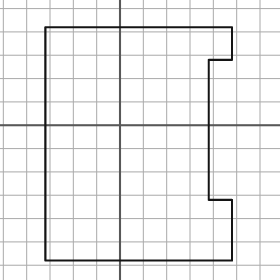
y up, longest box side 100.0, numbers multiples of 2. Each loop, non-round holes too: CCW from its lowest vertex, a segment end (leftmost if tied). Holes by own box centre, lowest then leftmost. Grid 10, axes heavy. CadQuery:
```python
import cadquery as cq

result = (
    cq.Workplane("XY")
    .moveTo(-32.0, -58.0)
    .lineTo(48.0, -58.0)
    .lineTo(48.0, -32.0)
    .lineTo(38.0, -32.0)
    .lineTo(38.0, 28.0)
    .lineTo(48.0, 28.0)
    .lineTo(48.0, 42.0)
    .lineTo(-32.0, 42.0)
    .close()
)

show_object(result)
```